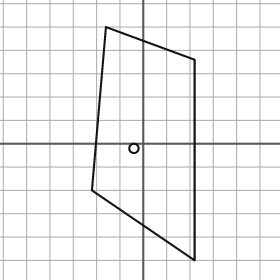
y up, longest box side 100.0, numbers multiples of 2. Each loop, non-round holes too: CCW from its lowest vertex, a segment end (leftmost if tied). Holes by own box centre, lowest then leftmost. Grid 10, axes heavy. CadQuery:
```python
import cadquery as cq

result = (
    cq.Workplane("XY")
    .moveTo(22.0, -50.0)
    .lineTo(22.0, 36.0)
    .lineTo(-16.0, 50.0)
    .lineTo(-22.0, -20.0)
    .close()
    .moveTo(-4.0, -2.0)
    .circle(2.0)
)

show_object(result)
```